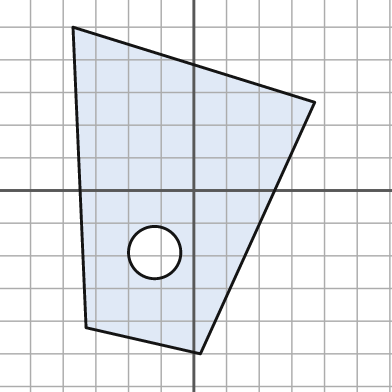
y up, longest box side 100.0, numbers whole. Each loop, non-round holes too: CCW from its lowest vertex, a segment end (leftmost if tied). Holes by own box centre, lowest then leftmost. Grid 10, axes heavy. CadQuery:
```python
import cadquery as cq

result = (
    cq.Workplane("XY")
    .moveTo(2.0, -50.0)
    .lineTo(37.0, 27.0)
    .lineTo(-37.0, 50.0)
    .lineTo(-33.0, -42.0)
    .close()
    .moveTo(-12.0, -19.0)
    .circle(8.0)
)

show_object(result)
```